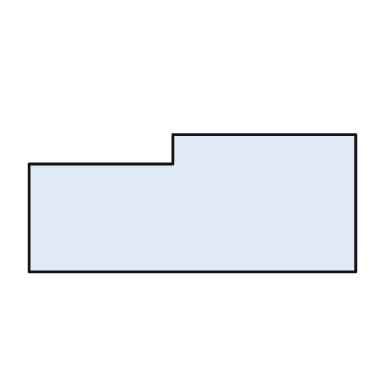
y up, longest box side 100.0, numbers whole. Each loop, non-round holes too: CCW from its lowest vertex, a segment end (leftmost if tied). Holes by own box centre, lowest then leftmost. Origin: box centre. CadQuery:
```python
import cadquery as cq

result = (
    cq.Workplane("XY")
    .moveTo(-50.0, -21.0)
    .lineTo(50.0, -21.0)
    .lineTo(50.0, 21.0)
    .lineTo(-6.0, 21.0)
    .lineTo(-6.0, 12.0)
    .lineTo(-50.0, 12.0)
    .close()
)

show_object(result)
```